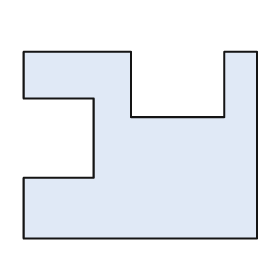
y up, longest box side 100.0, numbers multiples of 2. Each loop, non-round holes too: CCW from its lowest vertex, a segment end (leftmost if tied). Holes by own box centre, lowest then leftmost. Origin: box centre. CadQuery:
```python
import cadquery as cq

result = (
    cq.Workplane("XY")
    .moveTo(-50.0, -40.0)
    .lineTo(50.0, -40.0)
    .lineTo(50.0, 40.0)
    .lineTo(36.0, 40.0)
    .lineTo(36.0, 12.0)
    .lineTo(-4.0, 12.0)
    .lineTo(-4.0, 40.0)
    .lineTo(-50.0, 40.0)
    .lineTo(-50.0, 20.0)
    .lineTo(-20.0, 20.0)
    .lineTo(-20.0, -14.0)
    .lineTo(-50.0, -14.0)
    .close()
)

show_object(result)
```